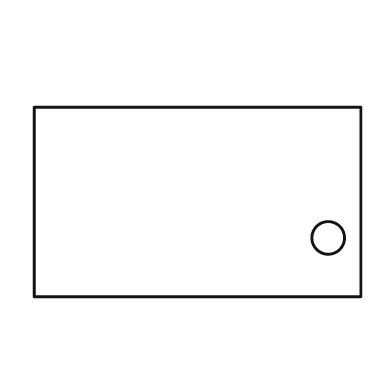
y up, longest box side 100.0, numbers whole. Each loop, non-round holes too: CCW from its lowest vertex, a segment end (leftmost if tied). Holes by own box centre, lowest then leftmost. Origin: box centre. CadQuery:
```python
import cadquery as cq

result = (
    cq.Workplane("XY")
    .moveTo(-50.0, -29.0)
    .lineTo(50.0, -29.0)
    .lineTo(50.0, 29.0)
    .lineTo(-50.0, 29.0)
    .close()
    .moveTo(40.0, -11.0)
    .circle(5.0)
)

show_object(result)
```